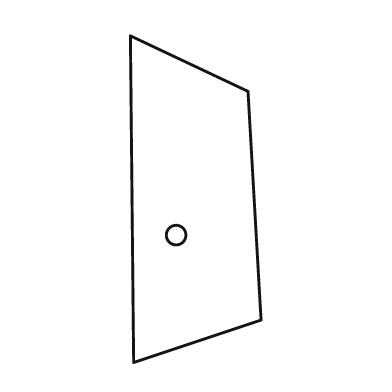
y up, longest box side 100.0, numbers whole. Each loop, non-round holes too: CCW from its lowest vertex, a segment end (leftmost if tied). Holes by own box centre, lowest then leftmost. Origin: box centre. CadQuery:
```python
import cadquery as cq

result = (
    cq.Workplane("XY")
    .moveTo(-19.0, -50.0)
    .lineTo(20.0, -37.0)
    .lineTo(16.0, 33.0)
    .lineTo(-20.0, 50.0)
    .close()
    .moveTo(-6.0, -11.0)
    .circle(3.0)
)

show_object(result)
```